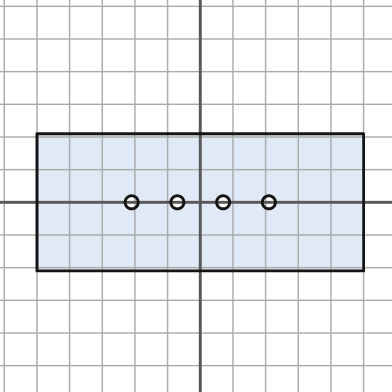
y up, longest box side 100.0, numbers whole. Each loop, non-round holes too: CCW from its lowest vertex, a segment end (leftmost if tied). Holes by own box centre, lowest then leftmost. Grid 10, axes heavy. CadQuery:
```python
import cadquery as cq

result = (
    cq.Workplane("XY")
    .moveTo(-50.0, -21.0)
    .lineTo(50.0, -21.0)
    .lineTo(50.0, 21.0)
    .lineTo(-50.0, 21.0)
    .close()
    .moveTo(-21.0, 0.0)
    .circle(2.0)
    .moveTo(-7.0, 0.0)
    .circle(2.0)
    .moveTo(7.0, 0.0)
    .circle(2.0)
    .moveTo(21.0, 0.0)
    .circle(2.0)
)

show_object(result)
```